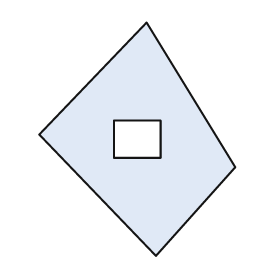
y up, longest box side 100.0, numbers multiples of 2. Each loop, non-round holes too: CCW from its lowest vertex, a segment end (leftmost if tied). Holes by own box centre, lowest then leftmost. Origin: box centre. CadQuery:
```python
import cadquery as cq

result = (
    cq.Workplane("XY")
    .moveTo(8.0, -50.0)
    .lineTo(42.0, -12.0)
    .lineTo(4.0, 50.0)
    .lineTo(-42.0, 2.0)
    .close()
    .moveTo(-10.0, -8.0)
    .lineTo(10.0, -8.0)
    .lineTo(10.0, 8.0)
    .lineTo(-10.0, 8.0)
    .close()
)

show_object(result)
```